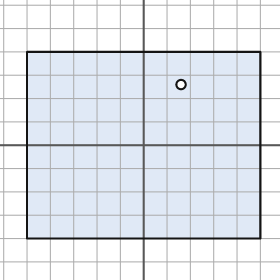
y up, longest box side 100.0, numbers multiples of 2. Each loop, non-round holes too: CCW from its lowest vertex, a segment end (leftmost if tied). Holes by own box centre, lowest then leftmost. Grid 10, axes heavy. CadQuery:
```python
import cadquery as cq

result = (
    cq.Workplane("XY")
    .moveTo(-50.0, -40.0)
    .lineTo(50.0, -40.0)
    .lineTo(50.0, 40.0)
    .lineTo(-50.0, 40.0)
    .close()
    .moveTo(16.0, 26.0)
    .circle(2.0)
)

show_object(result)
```